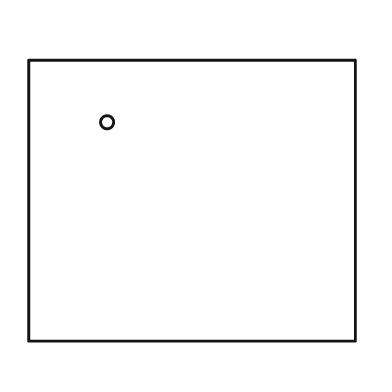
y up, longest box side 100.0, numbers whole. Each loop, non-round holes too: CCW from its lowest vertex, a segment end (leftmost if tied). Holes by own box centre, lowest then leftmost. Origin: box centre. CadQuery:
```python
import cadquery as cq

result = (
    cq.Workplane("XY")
    .moveTo(-50.0, -43.0)
    .lineTo(50.0, -43.0)
    .lineTo(50.0, 43.0)
    .lineTo(-50.0, 43.0)
    .close()
    .moveTo(-26.0, 24.0)
    .circle(2.0)
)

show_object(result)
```